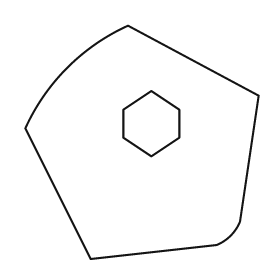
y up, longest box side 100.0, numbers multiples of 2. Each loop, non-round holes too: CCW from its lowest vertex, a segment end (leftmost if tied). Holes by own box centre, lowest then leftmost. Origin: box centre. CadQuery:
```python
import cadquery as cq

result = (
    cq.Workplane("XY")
    .moveTo(-22.0, -50.0)
    .lineTo(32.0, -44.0)
    .threePointArc((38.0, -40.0), (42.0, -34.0))
    .lineTo(50.0, 20.0)
    .lineTo(-6.0, 50.0)
    .threePointArc((-32.0, 32.0), (-50.0, 6.0))
    .close()
    .moveTo(4.0, -6.0)
    .lineTo(16.0, 2.0)
    .lineTo(16.0, 14.0)
    .lineTo(4.0, 22.0)
    .lineTo(-8.0, 14.0)
    .lineTo(-8.0, 2.0)
    .close()
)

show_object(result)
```